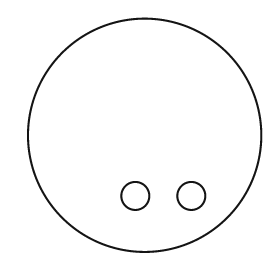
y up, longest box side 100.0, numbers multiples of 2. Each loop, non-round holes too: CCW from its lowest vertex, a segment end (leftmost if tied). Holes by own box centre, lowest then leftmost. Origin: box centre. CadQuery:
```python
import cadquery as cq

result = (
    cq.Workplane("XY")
    .moveTo(0.0, 0.0)
    .circle(50.0)
    .moveTo(-4.0, -26.0)
    .circle(6.0)
    .moveTo(20.0, -26.0)
    .circle(6.0)
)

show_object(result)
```